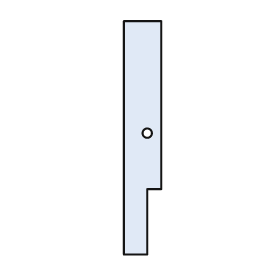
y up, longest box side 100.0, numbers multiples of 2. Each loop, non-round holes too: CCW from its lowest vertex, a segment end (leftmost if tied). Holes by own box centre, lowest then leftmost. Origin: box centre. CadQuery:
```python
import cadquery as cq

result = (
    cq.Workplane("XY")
    .moveTo(-8.0, -50.0)
    .lineTo(2.0, -50.0)
    .lineTo(2.0, -22.0)
    .lineTo(8.0, -22.0)
    .lineTo(8.0, 50.0)
    .lineTo(-8.0, 50.0)
    .close()
    .moveTo(2.0, 2.0)
    .circle(2.0)
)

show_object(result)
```